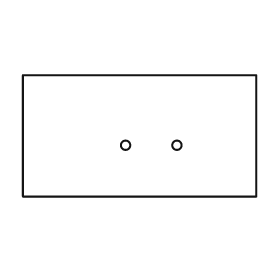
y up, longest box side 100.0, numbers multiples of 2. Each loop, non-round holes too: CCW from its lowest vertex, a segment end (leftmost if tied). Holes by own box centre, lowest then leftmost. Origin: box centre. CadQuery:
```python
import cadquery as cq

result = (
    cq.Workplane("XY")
    .moveTo(-50.0, -26.0)
    .lineTo(50.0, -26.0)
    .lineTo(50.0, 26.0)
    .lineTo(-50.0, 26.0)
    .close()
    .moveTo(-6.0, -4.0)
    .circle(2.0)
    .moveTo(16.0, -4.0)
    .circle(2.0)
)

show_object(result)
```